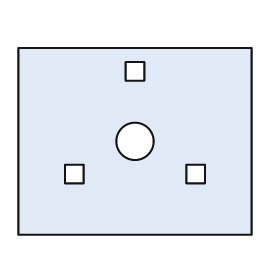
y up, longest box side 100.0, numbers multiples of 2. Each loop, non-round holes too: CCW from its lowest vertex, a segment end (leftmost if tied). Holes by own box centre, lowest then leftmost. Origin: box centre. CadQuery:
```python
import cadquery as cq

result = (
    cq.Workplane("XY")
    .moveTo(-50.0, -40.0)
    .lineTo(50.0, -40.0)
    .lineTo(50.0, 40.0)
    .lineTo(-50.0, 40.0)
    .close()
    .moveTo(-30.0, -18.0)
    .lineTo(-22.0, -18.0)
    .lineTo(-22.0, -10.0)
    .lineTo(-30.0, -10.0)
    .close()
    .moveTo(22.0, -18.0)
    .lineTo(30.0, -18.0)
    .lineTo(30.0, -10.0)
    .lineTo(22.0, -10.0)
    .close()
    .moveTo(0.0, 0.0)
    .circle(8.0)
    .moveTo(-4.0, 26.0)
    .lineTo(4.0, 26.0)
    .lineTo(4.0, 34.0)
    .lineTo(-4.0, 34.0)
    .close()
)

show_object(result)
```